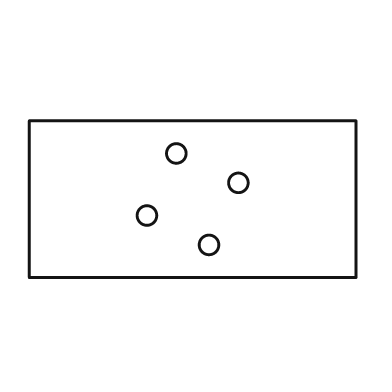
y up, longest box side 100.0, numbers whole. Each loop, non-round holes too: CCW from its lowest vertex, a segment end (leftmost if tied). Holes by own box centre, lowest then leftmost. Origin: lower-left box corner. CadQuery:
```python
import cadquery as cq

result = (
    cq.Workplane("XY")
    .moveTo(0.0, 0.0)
    .lineTo(100.0, 0.0)
    .lineTo(100.0, 48.0)
    .lineTo(0.0, 48.0)
    .close()
    .moveTo(55.0, 10.0)
    .circle(3.0)
    .moveTo(36.0, 19.0)
    .circle(3.0)
    .moveTo(64.0, 29.0)
    .circle(3.0)
    .moveTo(45.0, 38.0)
    .circle(3.0)
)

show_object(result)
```